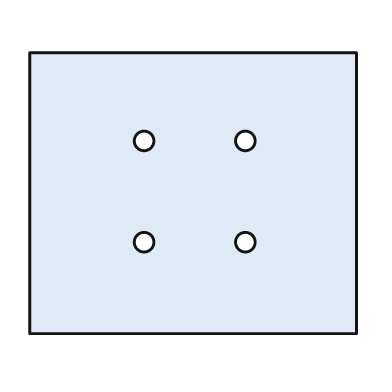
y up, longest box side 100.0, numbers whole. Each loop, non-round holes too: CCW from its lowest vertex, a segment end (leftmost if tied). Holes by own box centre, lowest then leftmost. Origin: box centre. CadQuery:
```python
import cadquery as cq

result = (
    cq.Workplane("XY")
    .moveTo(-50.0, -43.0)
    .lineTo(50.0, -43.0)
    .lineTo(50.0, 43.0)
    .lineTo(-50.0, 43.0)
    .close()
    .moveTo(-15.0, -15.0)
    .circle(3.0)
    .moveTo(16.0, -15.0)
    .circle(3.0)
    .moveTo(-15.0, 16.0)
    .circle(3.0)
    .moveTo(16.0, 16.0)
    .circle(3.0)
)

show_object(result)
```